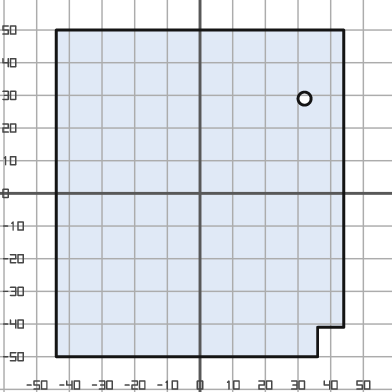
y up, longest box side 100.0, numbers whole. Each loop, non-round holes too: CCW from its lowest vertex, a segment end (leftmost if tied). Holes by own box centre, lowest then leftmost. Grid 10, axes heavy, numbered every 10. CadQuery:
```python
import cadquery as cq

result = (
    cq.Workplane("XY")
    .moveTo(-44.0, -50.0)
    .lineTo(36.0, -50.0)
    .lineTo(36.0, -41.0)
    .lineTo(44.0, -41.0)
    .lineTo(44.0, 50.0)
    .lineTo(-44.0, 50.0)
    .close()
    .moveTo(32.0, 29.0)
    .circle(2.0)
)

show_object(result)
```